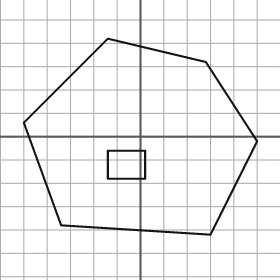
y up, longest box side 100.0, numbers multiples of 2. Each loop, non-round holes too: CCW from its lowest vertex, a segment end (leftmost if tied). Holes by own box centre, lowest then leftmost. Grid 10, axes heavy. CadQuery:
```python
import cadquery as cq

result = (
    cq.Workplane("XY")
    .moveTo(30.0, -42.0)
    .lineTo(50.0, -2.0)
    .lineTo(28.0, 32.0)
    .lineTo(-14.0, 42.0)
    .lineTo(-50.0, 6.0)
    .lineTo(-34.0, -38.0)
    .close()
    .moveTo(-14.0, -18.0)
    .lineTo(2.0, -18.0)
    .lineTo(2.0, -6.0)
    .lineTo(-14.0, -6.0)
    .close()
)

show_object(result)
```